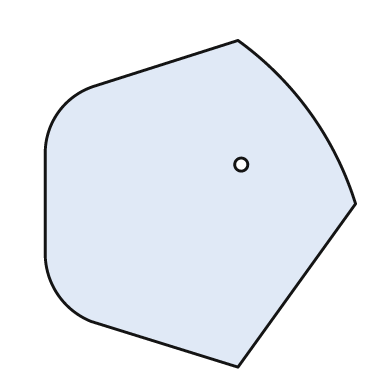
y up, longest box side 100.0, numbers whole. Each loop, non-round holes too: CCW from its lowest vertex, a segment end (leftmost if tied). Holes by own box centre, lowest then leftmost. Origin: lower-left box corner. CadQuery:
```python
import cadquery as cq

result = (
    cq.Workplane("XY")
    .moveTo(59.0, 0.0)
    .lineTo(95.0, 50.0)
    .threePointArc((81.0, 78.0), (59.0, 100.0))
    .lineTo(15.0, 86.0)
    .threePointArc((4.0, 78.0), (0.0, 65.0))
    .lineTo(0.0, 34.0)
    .threePointArc((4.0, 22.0), (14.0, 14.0))
    .close()
    .moveTo(60.0, 62.0)
    .circle(2.0)
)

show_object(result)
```